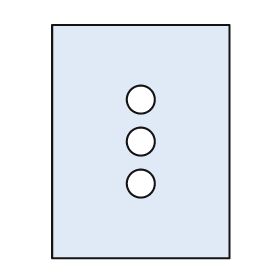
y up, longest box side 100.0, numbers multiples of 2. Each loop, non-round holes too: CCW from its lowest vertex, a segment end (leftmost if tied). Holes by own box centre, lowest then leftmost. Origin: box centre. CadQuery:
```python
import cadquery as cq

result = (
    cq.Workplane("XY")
    .moveTo(-38.0, -50.0)
    .lineTo(38.0, -50.0)
    .lineTo(38.0, 50.0)
    .lineTo(-38.0, 50.0)
    .close()
    .moveTo(0.0, -18.0)
    .circle(6.0)
    .moveTo(0.0, 0.0)
    .circle(6.0)
    .moveTo(0.0, 18.0)
    .circle(6.0)
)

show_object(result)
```